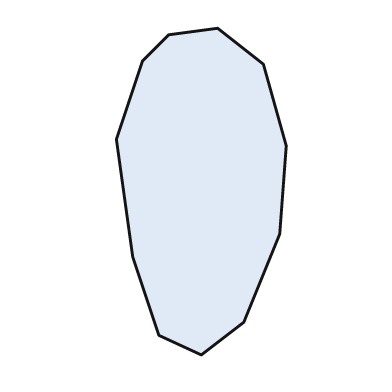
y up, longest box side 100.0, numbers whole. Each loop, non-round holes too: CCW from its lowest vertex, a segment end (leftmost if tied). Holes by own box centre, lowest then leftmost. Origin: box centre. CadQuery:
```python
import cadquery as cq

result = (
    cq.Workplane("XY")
    .moveTo(0.0, -50.0)
    .lineTo(13.0, -40.0)
    .lineTo(24.0, -13.0)
    .lineTo(26.0, 14.0)
    .lineTo(19.0, 39.0)
    .lineTo(5.0, 50.0)
    .lineTo(-10.0, 48.0)
    .lineTo(-18.0, 40.0)
    .lineTo(-26.0, 16.0)
    .lineTo(-21.0, -20.0)
    .lineTo(-13.0, -44.0)
    .close()
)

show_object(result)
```